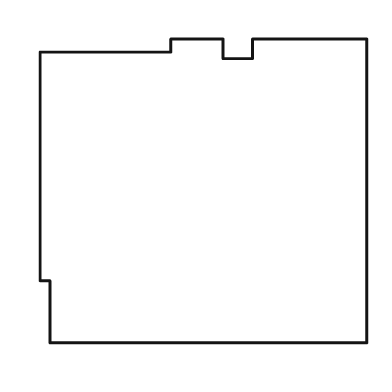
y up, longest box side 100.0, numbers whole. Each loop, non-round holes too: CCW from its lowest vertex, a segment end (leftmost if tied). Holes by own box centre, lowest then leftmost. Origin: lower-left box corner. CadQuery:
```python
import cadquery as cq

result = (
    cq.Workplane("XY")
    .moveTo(3.0, 0.0)
    .lineTo(100.0, 0.0)
    .lineTo(100.0, 93.0)
    .lineTo(65.0, 93.0)
    .lineTo(65.0, 87.0)
    .lineTo(56.0, 87.0)
    .lineTo(56.0, 93.0)
    .lineTo(40.0, 93.0)
    .lineTo(40.0, 89.0)
    .lineTo(0.0, 89.0)
    .lineTo(0.0, 19.0)
    .lineTo(3.0, 19.0)
    .close()
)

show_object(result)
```